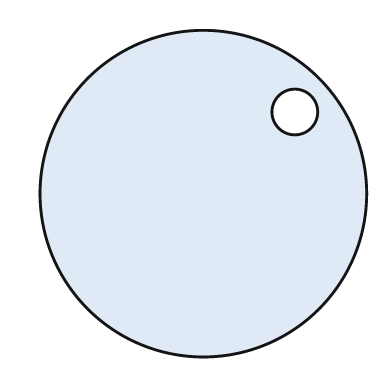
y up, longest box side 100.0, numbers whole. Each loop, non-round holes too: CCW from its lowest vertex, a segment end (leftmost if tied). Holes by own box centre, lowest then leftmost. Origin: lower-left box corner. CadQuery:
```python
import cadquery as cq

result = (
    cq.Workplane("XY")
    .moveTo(50.0, 50.0)
    .circle(50.0)
    .moveTo(78.0, 75.0)
    .circle(7.0)
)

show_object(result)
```